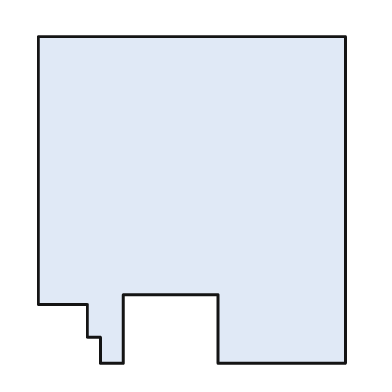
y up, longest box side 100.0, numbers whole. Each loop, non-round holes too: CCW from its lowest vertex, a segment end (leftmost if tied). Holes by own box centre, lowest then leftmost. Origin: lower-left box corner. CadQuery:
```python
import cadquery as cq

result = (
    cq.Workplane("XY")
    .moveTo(19.0, 0.0)
    .lineTo(26.0, 0.0)
    .lineTo(26.0, 21.0)
    .lineTo(55.0, 21.0)
    .lineTo(55.0, 0.0)
    .lineTo(94.0, 0.0)
    .lineTo(94.0, 100.0)
    .lineTo(0.0, 100.0)
    .lineTo(0.0, 18.0)
    .lineTo(15.0, 18.0)
    .lineTo(15.0, 8.0)
    .lineTo(19.0, 8.0)
    .close()
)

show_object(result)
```